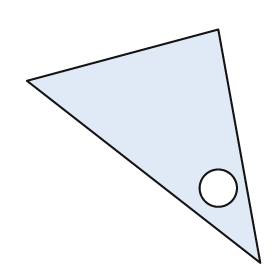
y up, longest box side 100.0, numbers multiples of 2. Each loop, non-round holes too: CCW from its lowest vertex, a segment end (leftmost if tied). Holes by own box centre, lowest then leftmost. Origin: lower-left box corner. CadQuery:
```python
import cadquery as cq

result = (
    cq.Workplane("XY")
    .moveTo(100.0, 0.0)
    .lineTo(82.0, 100.0)
    .lineTo(0.0, 78.0)
    .close()
    .moveTo(82.0, 32.0)
    .circle(8.0)
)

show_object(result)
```